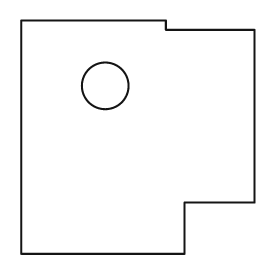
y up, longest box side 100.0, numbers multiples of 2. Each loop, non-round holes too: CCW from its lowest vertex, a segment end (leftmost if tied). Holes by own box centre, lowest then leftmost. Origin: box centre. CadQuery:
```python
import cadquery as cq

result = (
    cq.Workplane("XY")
    .moveTo(-50.0, -50.0)
    .lineTo(20.0, -50.0)
    .lineTo(20.0, -28.0)
    .lineTo(50.0, -28.0)
    .lineTo(50.0, 46.0)
    .lineTo(12.0, 46.0)
    .lineTo(12.0, 50.0)
    .lineTo(-50.0, 50.0)
    .close()
    .moveTo(-14.0, 22.0)
    .circle(10.0)
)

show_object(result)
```